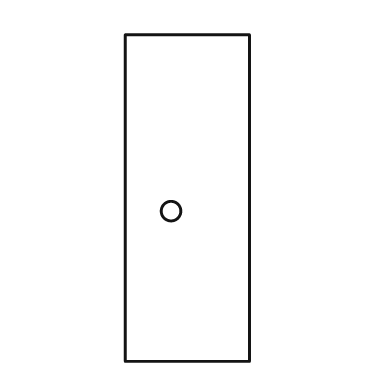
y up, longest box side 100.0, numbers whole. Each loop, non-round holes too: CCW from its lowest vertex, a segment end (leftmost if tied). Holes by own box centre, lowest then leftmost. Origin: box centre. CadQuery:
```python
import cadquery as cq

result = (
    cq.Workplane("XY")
    .moveTo(-19.0, -50.0)
    .lineTo(19.0, -50.0)
    .lineTo(19.0, 50.0)
    .lineTo(-19.0, 50.0)
    .close()
    .moveTo(-5.0, -4.0)
    .circle(3.0)
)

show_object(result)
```